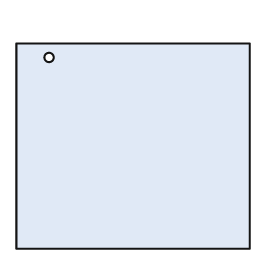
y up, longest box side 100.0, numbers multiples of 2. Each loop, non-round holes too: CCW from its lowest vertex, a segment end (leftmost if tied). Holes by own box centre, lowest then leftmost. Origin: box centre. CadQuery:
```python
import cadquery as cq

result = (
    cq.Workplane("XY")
    .moveTo(-50.0, -44.0)
    .lineTo(50.0, -44.0)
    .lineTo(50.0, 44.0)
    .lineTo(-50.0, 44.0)
    .close()
    .moveTo(-36.0, 38.0)
    .circle(2.0)
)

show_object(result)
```